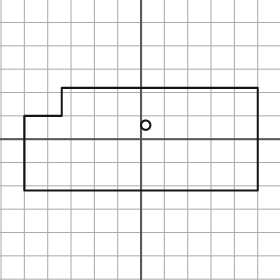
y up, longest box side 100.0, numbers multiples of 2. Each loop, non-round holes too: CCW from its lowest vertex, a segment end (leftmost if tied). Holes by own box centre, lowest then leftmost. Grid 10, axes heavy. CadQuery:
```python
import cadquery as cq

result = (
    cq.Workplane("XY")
    .moveTo(-50.0, -22.0)
    .lineTo(50.0, -22.0)
    .lineTo(50.0, 22.0)
    .lineTo(-34.0, 22.0)
    .lineTo(-34.0, 10.0)
    .lineTo(-50.0, 10.0)
    .close()
    .moveTo(2.0, 6.0)
    .circle(2.0)
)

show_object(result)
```